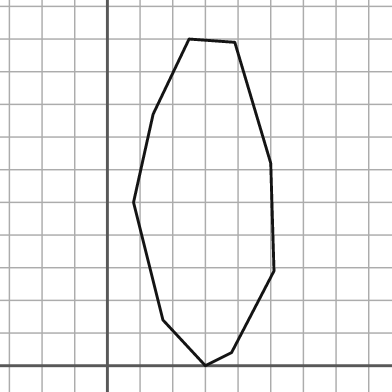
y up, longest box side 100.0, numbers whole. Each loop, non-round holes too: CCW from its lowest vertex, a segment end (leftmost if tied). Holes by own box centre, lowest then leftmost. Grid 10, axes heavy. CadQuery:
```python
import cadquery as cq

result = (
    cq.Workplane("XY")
    .moveTo(30.0, 0.0)
    .lineTo(38.0, 4.0)
    .lineTo(51.0, 29.0)
    .lineTo(50.0, 62.0)
    .lineTo(39.0, 99.0)
    .lineTo(25.0, 100.0)
    .lineTo(14.0, 77.0)
    .lineTo(8.0, 50.0)
    .lineTo(17.0, 14.0)
    .close()
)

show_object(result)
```